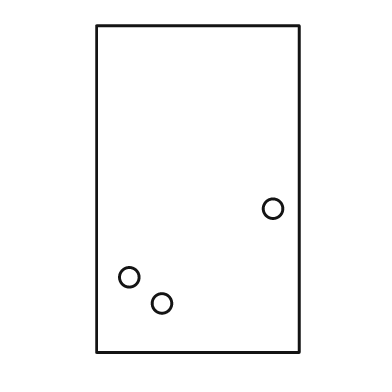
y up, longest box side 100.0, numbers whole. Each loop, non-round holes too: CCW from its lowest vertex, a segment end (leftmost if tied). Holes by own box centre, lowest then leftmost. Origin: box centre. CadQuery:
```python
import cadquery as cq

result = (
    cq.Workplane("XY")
    .moveTo(-31.0, -50.0)
    .lineTo(31.0, -50.0)
    .lineTo(31.0, 50.0)
    .lineTo(-31.0, 50.0)
    .close()
    .moveTo(-11.0, -35.0)
    .circle(3.0)
    .moveTo(-21.0, -27.0)
    .circle(3.0)
    .moveTo(23.0, -6.0)
    .circle(3.0)
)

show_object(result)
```